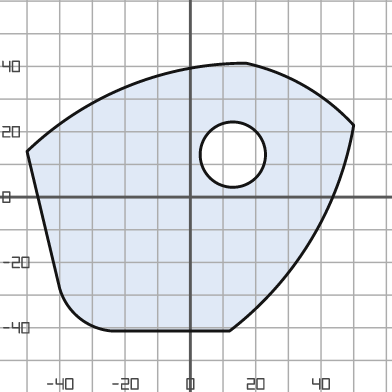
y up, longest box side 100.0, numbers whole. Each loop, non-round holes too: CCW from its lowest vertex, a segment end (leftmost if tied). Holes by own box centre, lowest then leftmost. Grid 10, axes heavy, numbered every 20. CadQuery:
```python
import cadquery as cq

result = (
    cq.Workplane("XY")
    .moveTo(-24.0, -41.0)
    .lineTo(12.0, -41.0)
    .threePointArc((37.0, -13.0), (50.0, 22.0))
    .threePointArc((35.0, 34.0), (17.0, 41.0))
    .threePointArc((-19.0, 34.0), (-50.0, 14.0))
    .lineTo(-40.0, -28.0)
    .threePointArc((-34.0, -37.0), (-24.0, -41.0))
    .close()
    .moveTo(13.0, 13.0)
    .circle(10.0)
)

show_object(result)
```